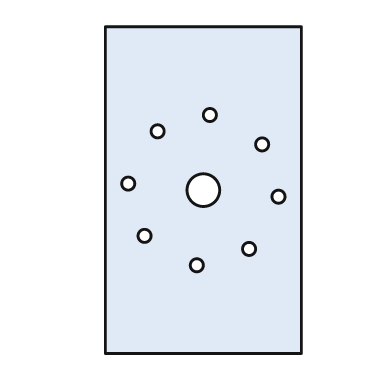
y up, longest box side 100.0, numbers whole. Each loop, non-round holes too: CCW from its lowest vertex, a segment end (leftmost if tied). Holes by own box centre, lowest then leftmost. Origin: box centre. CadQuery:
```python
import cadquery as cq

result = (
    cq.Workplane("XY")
    .moveTo(-30.0, -50.0)
    .lineTo(30.0, -50.0)
    .lineTo(30.0, 50.0)
    .lineTo(-30.0, 50.0)
    .close()
    .moveTo(-2.0, -23.0)
    .circle(2.0)
    .moveTo(14.0, -18.0)
    .circle(2.0)
    .moveTo(-18.0, -14.0)
    .circle(2.0)
    .moveTo(23.0, -2.0)
    .circle(2.0)
    .moveTo(0.0, 0.0)
    .circle(5.0)
    .moveTo(-23.0, 2.0)
    .circle(2.0)
    .moveTo(18.0, 14.0)
    .circle(2.0)
    .moveTo(-14.0, 18.0)
    .circle(2.0)
    .moveTo(2.0, 23.0)
    .circle(2.0)
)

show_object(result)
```